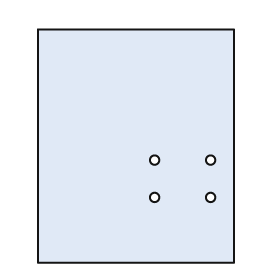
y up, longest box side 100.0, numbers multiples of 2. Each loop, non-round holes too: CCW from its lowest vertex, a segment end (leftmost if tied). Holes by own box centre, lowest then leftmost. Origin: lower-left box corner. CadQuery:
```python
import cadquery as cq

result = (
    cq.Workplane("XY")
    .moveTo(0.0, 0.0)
    .lineTo(84.0, 0.0)
    .lineTo(84.0, 100.0)
    .lineTo(0.0, 100.0)
    .close()
    .moveTo(50.0, 28.0)
    .circle(2.0)
    .moveTo(74.0, 28.0)
    .circle(2.0)
    .moveTo(50.0, 44.0)
    .circle(2.0)
    .moveTo(74.0, 44.0)
    .circle(2.0)
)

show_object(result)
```